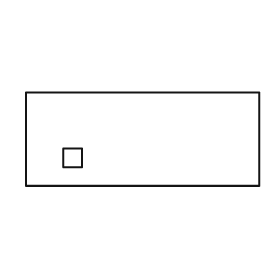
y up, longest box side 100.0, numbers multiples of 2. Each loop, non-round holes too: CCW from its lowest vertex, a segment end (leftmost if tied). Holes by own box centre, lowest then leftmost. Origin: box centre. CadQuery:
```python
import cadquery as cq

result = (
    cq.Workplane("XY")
    .moveTo(-50.0, -20.0)
    .lineTo(50.0, -20.0)
    .lineTo(50.0, 20.0)
    .lineTo(-50.0, 20.0)
    .close()
    .moveTo(-34.0, -12.0)
    .lineTo(-26.0, -12.0)
    .lineTo(-26.0, -4.0)
    .lineTo(-34.0, -4.0)
    .close()
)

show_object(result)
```